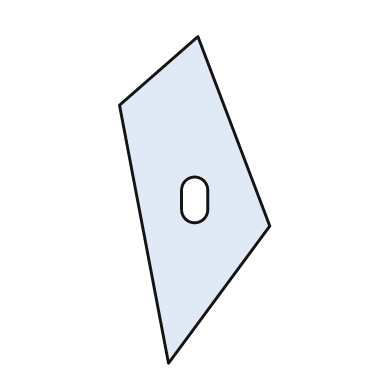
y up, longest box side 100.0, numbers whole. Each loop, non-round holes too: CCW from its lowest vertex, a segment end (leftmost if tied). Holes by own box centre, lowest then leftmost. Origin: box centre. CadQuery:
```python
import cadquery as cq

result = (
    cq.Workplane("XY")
    .moveTo(-8.0, -50.0)
    .lineTo(23.0, -8.0)
    .lineTo(1.0, 50.0)
    .lineTo(-23.0, 29.0)
    .close()
    .moveTo(-4.0, -3.0)
    .threePointArc((0.0, -7.0), (4.0, -3.0))
    .lineTo(4.0, 3.0)
    .threePointArc((0.0, 7.0), (-4.0, 3.0))
    .close()
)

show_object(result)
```